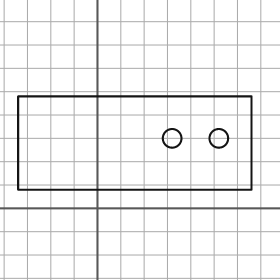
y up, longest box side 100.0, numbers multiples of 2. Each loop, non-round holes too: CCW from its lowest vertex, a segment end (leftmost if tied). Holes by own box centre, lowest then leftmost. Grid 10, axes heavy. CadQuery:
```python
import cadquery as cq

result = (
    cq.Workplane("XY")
    .moveTo(-34.0, 8.0)
    .lineTo(66.0, 8.0)
    .lineTo(66.0, 48.0)
    .lineTo(-34.0, 48.0)
    .close()
    .moveTo(32.0, 30.0)
    .circle(4.0)
    .moveTo(52.0, 30.0)
    .circle(4.0)
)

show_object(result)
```